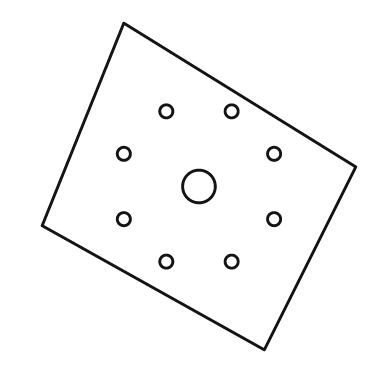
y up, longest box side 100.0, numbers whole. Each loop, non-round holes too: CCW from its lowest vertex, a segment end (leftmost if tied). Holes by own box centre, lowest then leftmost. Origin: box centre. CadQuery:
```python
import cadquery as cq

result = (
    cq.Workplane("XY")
    .moveTo(20.0, -50.0)
    .lineTo(48.0, 6.0)
    .lineTo(-23.0, 50.0)
    .lineTo(-48.0, -12.0)
    .close()
    .moveTo(-10.0, -23.0)
    .circle(2.0)
    .moveTo(10.0, -23.0)
    .circle(2.0)
    .moveTo(-23.0, -10.0)
    .circle(2.0)
    .moveTo(23.0, -10.0)
    .circle(2.0)
    .moveTo(0.0, 0.0)
    .circle(5.0)
    .moveTo(-23.0, 10.0)
    .circle(2.0)
    .moveTo(23.0, 10.0)
    .circle(2.0)
    .moveTo(-10.0, 23.0)
    .circle(2.0)
    .moveTo(10.0, 23.0)
    .circle(2.0)
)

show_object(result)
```